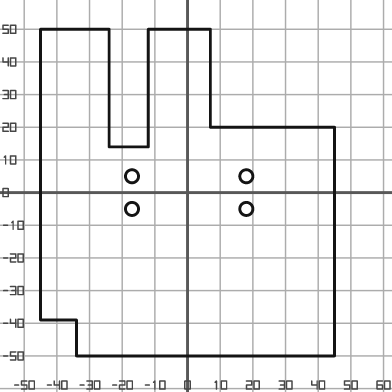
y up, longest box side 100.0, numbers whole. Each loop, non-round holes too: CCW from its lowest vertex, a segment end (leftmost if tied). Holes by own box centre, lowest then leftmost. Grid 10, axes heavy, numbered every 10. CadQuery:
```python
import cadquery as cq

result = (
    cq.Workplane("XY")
    .moveTo(-34.0, -50.0)
    .lineTo(45.0, -50.0)
    .lineTo(45.0, 20.0)
    .lineTo(7.0, 20.0)
    .lineTo(7.0, 50.0)
    .lineTo(-12.0, 50.0)
    .lineTo(-12.0, 14.0)
    .lineTo(-24.0, 14.0)
    .lineTo(-24.0, 50.0)
    .lineTo(-45.0, 50.0)
    .lineTo(-45.0, -39.0)
    .lineTo(-34.0, -39.0)
    .close()
    .moveTo(-17.0, -5.0)
    .circle(2.0)
    .moveTo(18.0, -5.0)
    .circle(2.0)
    .moveTo(-17.0, 5.0)
    .circle(2.0)
    .moveTo(18.0, 5.0)
    .circle(2.0)
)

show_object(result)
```